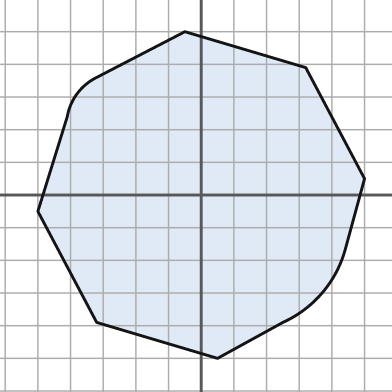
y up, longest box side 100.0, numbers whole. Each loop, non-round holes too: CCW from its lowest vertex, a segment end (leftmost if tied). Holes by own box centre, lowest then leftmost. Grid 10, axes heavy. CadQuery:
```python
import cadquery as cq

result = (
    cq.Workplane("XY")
    .moveTo(5.0, -50.0)
    .lineTo(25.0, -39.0)
    .threePointArc((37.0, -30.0), (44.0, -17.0))
    .lineTo(50.0, 5.0)
    .lineTo(32.0, 39.0)
    .lineTo(-5.0, 50.0)
    .lineTo(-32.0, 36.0)
    .threePointArc((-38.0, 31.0), (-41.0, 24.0))
    .lineTo(-50.0, -5.0)
    .lineTo(-32.0, -39.0)
    .close()
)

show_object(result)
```